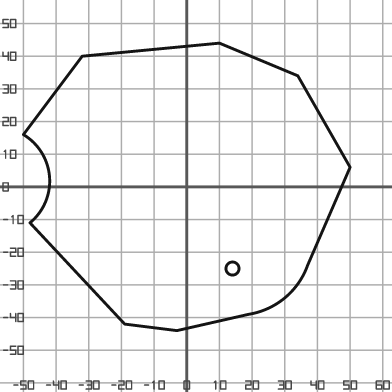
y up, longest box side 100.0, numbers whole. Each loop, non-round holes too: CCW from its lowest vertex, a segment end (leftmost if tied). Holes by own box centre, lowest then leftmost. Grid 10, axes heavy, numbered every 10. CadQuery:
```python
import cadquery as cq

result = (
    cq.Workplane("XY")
    .moveTo(-3.0, -44.0)
    .lineTo(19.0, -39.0)
    .threePointArc((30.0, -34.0), (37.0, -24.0))
    .lineTo(50.0, 6.0)
    .lineTo(34.0, 34.0)
    .lineTo(10.0, 44.0)
    .lineTo(-32.0, 40.0)
    .lineTo(-50.0, 16.0)
    .threePointArc((-42.0, 3.0), (-48.0, -11.0))
    .lineTo(-19.0, -42.0)
    .close()
    .moveTo(14.0, -25.0)
    .circle(2.0)
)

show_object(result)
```